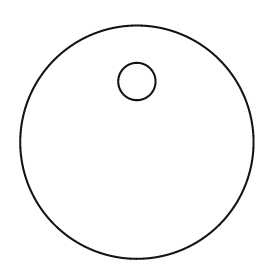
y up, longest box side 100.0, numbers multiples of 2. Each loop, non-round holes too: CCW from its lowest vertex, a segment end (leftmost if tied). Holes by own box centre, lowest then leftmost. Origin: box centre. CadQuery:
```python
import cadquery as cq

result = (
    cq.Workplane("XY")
    .moveTo(0.0, 0.0)
    .circle(50.0)
    .moveTo(0.0, 26.0)
    .circle(8.0)
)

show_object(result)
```